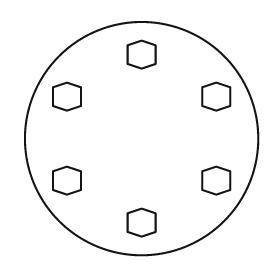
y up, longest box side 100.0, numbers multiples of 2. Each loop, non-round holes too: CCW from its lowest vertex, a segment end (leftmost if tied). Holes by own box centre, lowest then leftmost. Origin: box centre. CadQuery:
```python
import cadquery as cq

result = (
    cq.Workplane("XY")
    .moveTo(0.0, 0.0)
    .circle(50.0)
    .moveTo(0.0, -42.0)
    .lineTo(6.0, -40.0)
    .lineTo(6.0, -32.0)
    .lineTo(0.0, -30.0)
    .lineTo(-6.0, -32.0)
    .lineTo(-6.0, -40.0)
    .close()
    .moveTo(-32.0, -24.0)
    .lineTo(-26.0, -22.0)
    .lineTo(-26.0, -14.0)
    .lineTo(-32.0, -12.0)
    .lineTo(-38.0, -14.0)
    .lineTo(-38.0, -22.0)
    .close()
    .moveTo(32.0, -24.0)
    .lineTo(38.0, -22.0)
    .lineTo(38.0, -14.0)
    .lineTo(32.0, -12.0)
    .lineTo(26.0, -14.0)
    .lineTo(26.0, -22.0)
    .close()
    .moveTo(-32.0, 12.0)
    .lineTo(-26.0, 14.0)
    .lineTo(-26.0, 22.0)
    .lineTo(-32.0, 24.0)
    .lineTo(-38.0, 22.0)
    .lineTo(-38.0, 14.0)
    .close()
    .moveTo(32.0, 12.0)
    .lineTo(38.0, 14.0)
    .lineTo(38.0, 22.0)
    .lineTo(32.0, 24.0)
    .lineTo(26.0, 22.0)
    .lineTo(26.0, 14.0)
    .close()
    .moveTo(0.0, 30.0)
    .lineTo(6.0, 32.0)
    .lineTo(6.0, 40.0)
    .lineTo(0.0, 42.0)
    .lineTo(-6.0, 40.0)
    .lineTo(-6.0, 32.0)
    .close()
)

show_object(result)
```